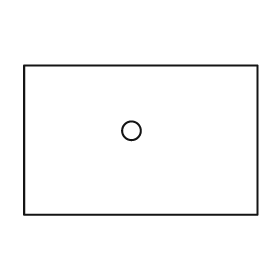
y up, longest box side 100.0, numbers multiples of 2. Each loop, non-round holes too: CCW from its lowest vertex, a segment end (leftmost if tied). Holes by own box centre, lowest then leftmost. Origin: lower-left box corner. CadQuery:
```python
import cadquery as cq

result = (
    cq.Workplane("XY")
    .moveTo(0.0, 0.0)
    .lineTo(100.0, 0.0)
    .lineTo(100.0, 64.0)
    .lineTo(0.0, 64.0)
    .close()
    .moveTo(46.0, 36.0)
    .circle(4.0)
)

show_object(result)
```